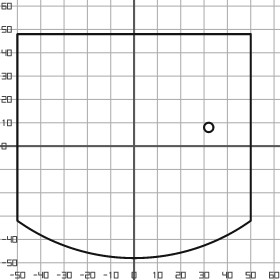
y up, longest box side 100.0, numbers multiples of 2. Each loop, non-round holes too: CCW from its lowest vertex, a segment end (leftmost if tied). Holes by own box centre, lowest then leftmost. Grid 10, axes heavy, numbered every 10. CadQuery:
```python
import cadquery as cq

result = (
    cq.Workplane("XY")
    .moveTo(-50.0, -32.0)
    .threePointArc((0.0, -48.0), (50.0, -32.0))
    .lineTo(50.0, 48.0)
    .lineTo(-50.0, 48.0)
    .close()
    .moveTo(32.0, 8.0)
    .circle(2.0)
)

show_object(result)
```